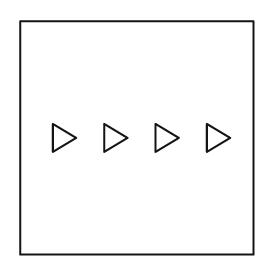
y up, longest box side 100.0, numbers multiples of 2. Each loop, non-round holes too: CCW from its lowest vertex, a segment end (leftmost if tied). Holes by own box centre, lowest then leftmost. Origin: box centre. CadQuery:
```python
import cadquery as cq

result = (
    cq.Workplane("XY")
    .moveTo(-50.0, -50.0)
    .lineTo(50.0, -50.0)
    .lineTo(50.0, 50.0)
    .lineTo(-50.0, 50.0)
    .close()
    .moveTo(-36.0, -6.0)
    .lineTo(-26.0, 0.0)
    .lineTo(-36.0, 6.0)
    .close()
    .moveTo(-14.0, -6.0)
    .lineTo(-4.0, 0.0)
    .lineTo(-14.0, 6.0)
    .close()
    .moveTo(8.0, -6.0)
    .lineTo(18.0, 0.0)
    .lineTo(8.0, 6.0)
    .close()
    .moveTo(30.0, -6.0)
    .lineTo(40.0, 0.0)
    .lineTo(30.0, 6.0)
    .close()
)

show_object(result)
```